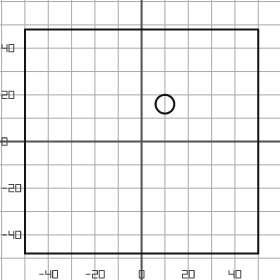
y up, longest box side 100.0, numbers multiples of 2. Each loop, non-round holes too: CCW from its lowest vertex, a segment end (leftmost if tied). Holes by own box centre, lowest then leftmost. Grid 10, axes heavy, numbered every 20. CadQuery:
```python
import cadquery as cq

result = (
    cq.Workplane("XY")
    .moveTo(-50.0, -48.0)
    .lineTo(50.0, -48.0)
    .lineTo(50.0, 48.0)
    .lineTo(-50.0, 48.0)
    .close()
    .moveTo(10.0, 16.0)
    .circle(4.0)
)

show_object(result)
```